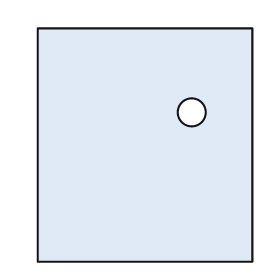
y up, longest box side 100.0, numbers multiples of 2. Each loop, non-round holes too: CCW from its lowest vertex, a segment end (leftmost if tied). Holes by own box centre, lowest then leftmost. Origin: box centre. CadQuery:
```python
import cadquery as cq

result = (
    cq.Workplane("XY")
    .moveTo(-46.0, -50.0)
    .lineTo(46.0, -50.0)
    .lineTo(46.0, 50.0)
    .lineTo(-46.0, 50.0)
    .close()
    .moveTo(20.0, 14.0)
    .circle(6.0)
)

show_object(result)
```